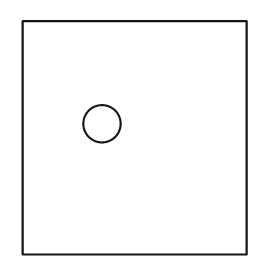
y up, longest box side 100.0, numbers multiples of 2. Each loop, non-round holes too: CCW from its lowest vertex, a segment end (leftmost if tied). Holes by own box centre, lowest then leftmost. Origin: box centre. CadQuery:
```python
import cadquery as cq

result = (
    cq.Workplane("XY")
    .moveTo(-48.0, -50.0)
    .lineTo(48.0, -50.0)
    .lineTo(48.0, 50.0)
    .lineTo(-48.0, 50.0)
    .close()
    .moveTo(-14.0, 6.0)
    .circle(8.0)
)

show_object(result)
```